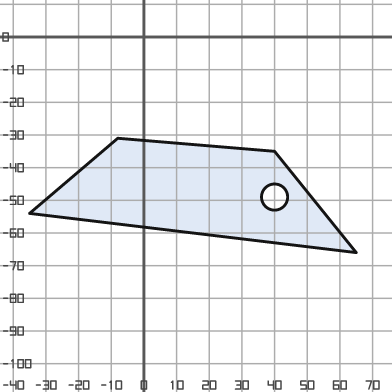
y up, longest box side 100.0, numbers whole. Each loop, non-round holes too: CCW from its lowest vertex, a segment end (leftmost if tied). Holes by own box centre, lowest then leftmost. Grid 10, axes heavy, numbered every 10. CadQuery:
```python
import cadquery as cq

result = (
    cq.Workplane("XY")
    .moveTo(65.0, -66.0)
    .lineTo(40.0, -35.0)
    .lineTo(-8.0, -31.0)
    .lineTo(-35.0, -54.0)
    .close()
    .moveTo(40.0, -49.0)
    .circle(4.0)
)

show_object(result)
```